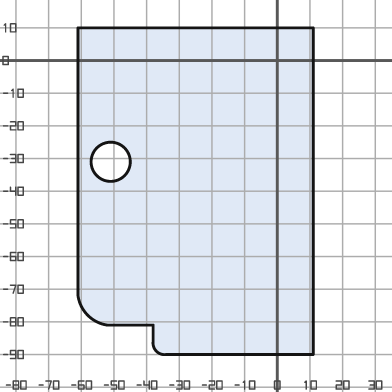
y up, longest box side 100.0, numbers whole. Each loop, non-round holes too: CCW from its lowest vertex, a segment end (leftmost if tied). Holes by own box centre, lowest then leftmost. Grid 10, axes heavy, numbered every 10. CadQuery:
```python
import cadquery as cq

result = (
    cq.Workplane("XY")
    .moveTo(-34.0, -90.0)
    .lineTo(11.0, -90.0)
    .lineTo(11.0, 10.0)
    .lineTo(-61.0, 10.0)
    .lineTo(-61.0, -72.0)
    .threePointArc((-58.0, -78.0), (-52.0, -81.0))
    .lineTo(-38.0, -81.0)
    .lineTo(-38.0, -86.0)
    .threePointArc((-37.0, -89.0), (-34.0, -90.0))
    .close()
    .moveTo(-51.0, -31.0)
    .circle(6.0)
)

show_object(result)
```